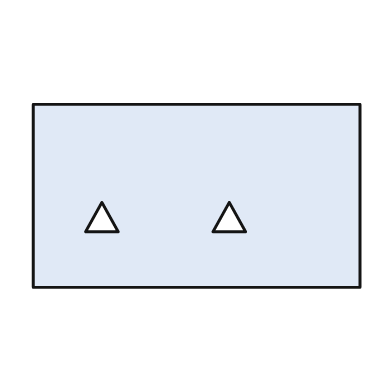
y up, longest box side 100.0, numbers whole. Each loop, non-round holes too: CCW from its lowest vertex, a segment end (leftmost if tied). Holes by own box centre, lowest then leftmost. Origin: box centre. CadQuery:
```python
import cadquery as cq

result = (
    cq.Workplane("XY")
    .moveTo(-50.0, -28.0)
    .lineTo(50.0, -28.0)
    .lineTo(50.0, 28.0)
    .lineTo(-50.0, 28.0)
    .close()
    .moveTo(-34.0, -11.0)
    .lineTo(-24.0, -11.0)
    .lineTo(-29.0, -2.0)
    .close()
    .moveTo(5.0, -11.0)
    .lineTo(15.0, -11.0)
    .lineTo(10.0, -2.0)
    .close()
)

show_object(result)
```